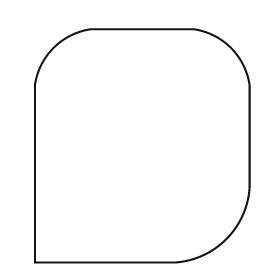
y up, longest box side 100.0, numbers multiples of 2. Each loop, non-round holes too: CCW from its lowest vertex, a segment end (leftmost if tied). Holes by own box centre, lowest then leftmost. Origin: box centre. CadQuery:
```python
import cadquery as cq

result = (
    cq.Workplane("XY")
    .moveTo(-46.0, -50.0)
    .lineTo(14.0, -50.0)
    .threePointArc((36.0, -40.0), (46.0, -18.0))
    .lineTo(46.0, 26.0)
    .threePointArc((38.0, 42.0), (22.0, 50.0))
    .lineTo(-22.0, 50.0)
    .threePointArc((-38.0, 42.0), (-46.0, 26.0))
    .close()
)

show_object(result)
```